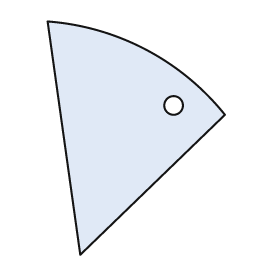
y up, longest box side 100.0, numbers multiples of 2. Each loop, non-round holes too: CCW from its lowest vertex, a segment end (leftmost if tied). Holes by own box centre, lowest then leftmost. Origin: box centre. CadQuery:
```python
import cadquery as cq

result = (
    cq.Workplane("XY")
    .moveTo(-24.0, -50.0)
    .lineTo(38.0, 10.0)
    .threePointArc((4.0, 38.0), (-38.0, 50.0))
    .close()
    .moveTo(16.0, 14.0)
    .circle(4.0)
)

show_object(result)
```